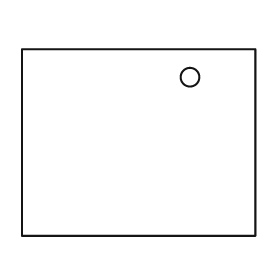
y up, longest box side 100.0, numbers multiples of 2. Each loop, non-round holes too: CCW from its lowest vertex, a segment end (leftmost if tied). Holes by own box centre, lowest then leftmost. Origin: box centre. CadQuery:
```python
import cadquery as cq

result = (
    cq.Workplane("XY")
    .moveTo(-50.0, -40.0)
    .lineTo(50.0, -40.0)
    .lineTo(50.0, 40.0)
    .lineTo(-50.0, 40.0)
    .close()
    .moveTo(22.0, 28.0)
    .circle(4.0)
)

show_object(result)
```